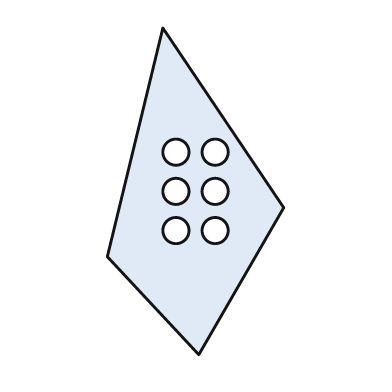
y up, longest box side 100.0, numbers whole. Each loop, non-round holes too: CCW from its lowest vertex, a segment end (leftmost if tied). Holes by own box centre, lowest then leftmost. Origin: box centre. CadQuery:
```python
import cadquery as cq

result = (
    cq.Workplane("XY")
    .moveTo(1.0, -50.0)
    .lineTo(27.0, -5.0)
    .lineTo(-10.0, 50.0)
    .lineTo(-27.0, -20.0)
    .close()
    .moveTo(-6.0, -12.0)
    .circle(4.0)
    .moveTo(6.0, -12.0)
    .circle(4.0)
    .moveTo(-6.0, 0.0)
    .circle(4.0)
    .moveTo(6.0, 0.0)
    .circle(4.0)
    .moveTo(-6.0, 12.0)
    .circle(4.0)
    .moveTo(6.0, 12.0)
    .circle(4.0)
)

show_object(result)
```